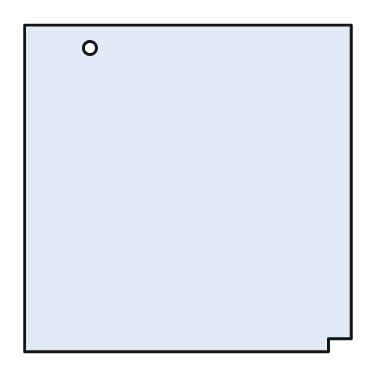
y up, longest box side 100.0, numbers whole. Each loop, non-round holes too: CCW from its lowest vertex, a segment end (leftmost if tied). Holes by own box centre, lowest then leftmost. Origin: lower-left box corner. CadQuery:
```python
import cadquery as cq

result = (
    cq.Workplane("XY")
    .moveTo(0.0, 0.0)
    .lineTo(93.0, 0.0)
    .lineTo(93.0, 4.0)
    .lineTo(100.0, 4.0)
    .lineTo(100.0, 100.0)
    .lineTo(0.0, 100.0)
    .close()
    .moveTo(20.0, 93.0)
    .circle(2.0)
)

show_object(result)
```